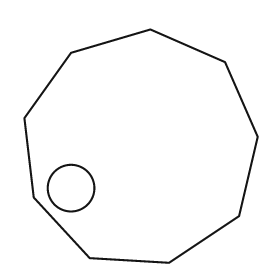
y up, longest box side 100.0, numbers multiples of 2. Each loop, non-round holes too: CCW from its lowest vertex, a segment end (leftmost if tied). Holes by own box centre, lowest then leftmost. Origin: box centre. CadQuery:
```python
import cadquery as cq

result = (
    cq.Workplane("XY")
    .moveTo(12.0, -50.0)
    .lineTo(42.0, -30.0)
    .lineTo(50.0, 4.0)
    .lineTo(36.0, 36.0)
    .lineTo(4.0, 50.0)
    .lineTo(-30.0, 40.0)
    .lineTo(-50.0, 12.0)
    .lineTo(-46.0, -22.0)
    .lineTo(-22.0, -48.0)
    .close()
    .moveTo(-30.0, -18.0)
    .circle(10.0)
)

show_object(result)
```